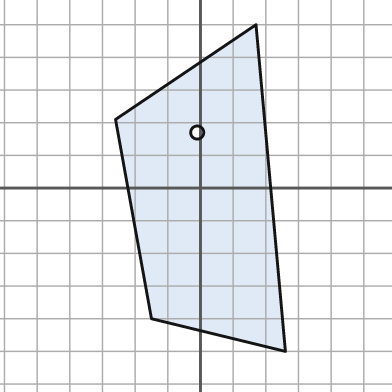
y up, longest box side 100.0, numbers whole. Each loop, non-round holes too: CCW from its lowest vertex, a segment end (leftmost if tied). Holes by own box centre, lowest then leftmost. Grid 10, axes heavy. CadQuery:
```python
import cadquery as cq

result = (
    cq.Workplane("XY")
    .moveTo(26.0, -50.0)
    .lineTo(17.0, 50.0)
    .lineTo(-26.0, 21.0)
    .lineTo(-15.0, -40.0)
    .close()
    .moveTo(-1.0, 17.0)
    .circle(2.0)
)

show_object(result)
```